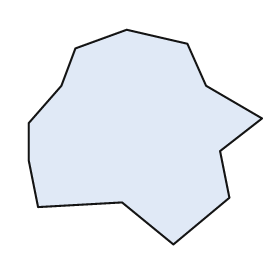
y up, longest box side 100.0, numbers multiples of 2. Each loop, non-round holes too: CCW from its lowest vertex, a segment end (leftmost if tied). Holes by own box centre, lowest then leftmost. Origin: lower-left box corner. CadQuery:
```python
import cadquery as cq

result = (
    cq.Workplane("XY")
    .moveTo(62.0, 0.0)
    .lineTo(86.0, 20.0)
    .lineTo(82.0, 40.0)
    .lineTo(100.0, 54.0)
    .lineTo(76.0, 68.0)
    .lineTo(68.0, 86.0)
    .lineTo(42.0, 92.0)
    .lineTo(20.0, 84.0)
    .lineTo(14.0, 68.0)
    .lineTo(0.0, 52.0)
    .lineTo(0.0, 36.0)
    .lineTo(4.0, 16.0)
    .lineTo(40.0, 18.0)
    .close()
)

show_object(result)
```